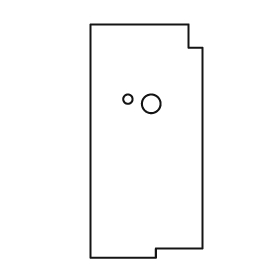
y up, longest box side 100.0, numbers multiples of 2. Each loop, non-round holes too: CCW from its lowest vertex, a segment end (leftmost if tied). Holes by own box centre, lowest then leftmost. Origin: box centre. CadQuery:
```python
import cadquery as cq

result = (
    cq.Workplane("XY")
    .moveTo(-24.0, -50.0)
    .lineTo(4.0, -50.0)
    .lineTo(4.0, -46.0)
    .lineTo(24.0, -46.0)
    .lineTo(24.0, 40.0)
    .lineTo(18.0, 40.0)
    .lineTo(18.0, 50.0)
    .lineTo(-24.0, 50.0)
    .close()
    .moveTo(2.0, 16.0)
    .circle(4.0)
    .moveTo(-8.0, 18.0)
    .circle(2.0)
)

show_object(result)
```